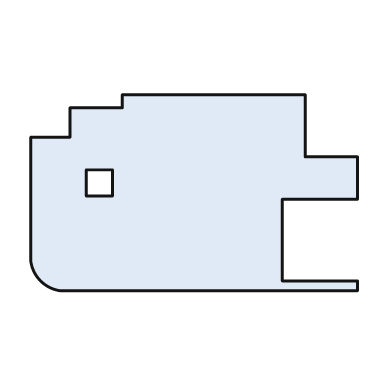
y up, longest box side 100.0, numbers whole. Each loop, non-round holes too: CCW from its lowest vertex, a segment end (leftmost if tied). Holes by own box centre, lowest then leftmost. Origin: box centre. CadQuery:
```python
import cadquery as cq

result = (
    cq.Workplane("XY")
    .moveTo(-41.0, -30.0)
    .lineTo(50.0, -30.0)
    .lineTo(50.0, -27.0)
    .lineTo(27.0, -27.0)
    .lineTo(27.0, -2.0)
    .lineTo(50.0, -2.0)
    .lineTo(50.0, 11.0)
    .lineTo(34.0, 11.0)
    .lineTo(34.0, 30.0)
    .lineTo(-22.0, 30.0)
    .lineTo(-22.0, 26.0)
    .lineTo(-38.0, 26.0)
    .lineTo(-38.0, 17.0)
    .lineTo(-50.0, 17.0)
    .lineTo(-50.0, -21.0)
    .threePointArc((-47.0, -27.0), (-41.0, -30.0))
    .close()
    .moveTo(-33.0, -1.0)
    .lineTo(-25.0, -1.0)
    .lineTo(-25.0, 7.0)
    .lineTo(-33.0, 7.0)
    .close()
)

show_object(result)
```